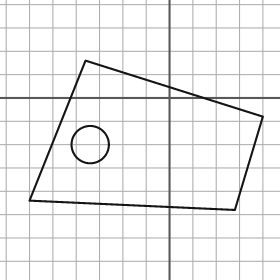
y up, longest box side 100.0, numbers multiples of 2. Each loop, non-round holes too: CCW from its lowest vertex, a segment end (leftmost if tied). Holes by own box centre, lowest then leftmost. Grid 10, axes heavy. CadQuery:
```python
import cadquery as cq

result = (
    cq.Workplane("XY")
    .moveTo(28.0, -48.0)
    .lineTo(40.0, -8.0)
    .lineTo(-36.0, 16.0)
    .lineTo(-60.0, -44.0)
    .close()
    .moveTo(-34.0, -20.0)
    .circle(8.0)
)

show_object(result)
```